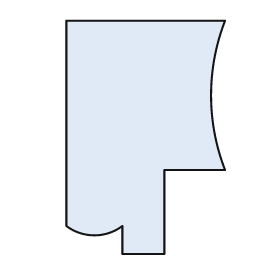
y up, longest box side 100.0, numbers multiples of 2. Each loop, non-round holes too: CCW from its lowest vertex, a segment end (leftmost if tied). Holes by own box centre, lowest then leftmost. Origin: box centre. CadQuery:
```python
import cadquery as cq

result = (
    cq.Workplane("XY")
    .moveTo(-10.0, -50.0)
    .lineTo(8.0, -50.0)
    .lineTo(8.0, -14.0)
    .lineTo(34.0, -14.0)
    .threePointArc((28.0, 18.0), (34.0, 50.0))
    .lineTo(-34.0, 50.0)
    .lineTo(-34.0, -38.0)
    .threePointArc((-22.0, -42.0), (-10.0, -38.0))
    .close()
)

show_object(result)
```